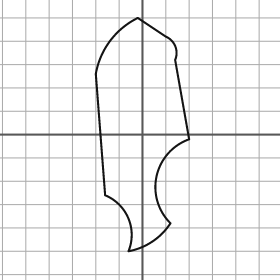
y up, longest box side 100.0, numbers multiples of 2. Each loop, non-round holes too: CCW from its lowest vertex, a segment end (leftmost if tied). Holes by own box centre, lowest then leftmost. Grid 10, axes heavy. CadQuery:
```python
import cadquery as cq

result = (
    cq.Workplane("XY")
    .moveTo(-6.0, -50.0)
    .threePointArc((4.0, -46.0), (12.0, -38.0))
    .threePointArc((6.0, -18.0), (20.0, -2.0))
    .lineTo(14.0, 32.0)
    .threePointArc((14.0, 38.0), (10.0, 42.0))
    .lineTo(-2.0, 50.0)
    .threePointArc((-14.0, 40.0), (-20.0, 26.0))
    .lineTo(-16.0, -26.0)
    .threePointArc((-6.0, -36.0), (-6.0, -50.0))
    .close()
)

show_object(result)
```